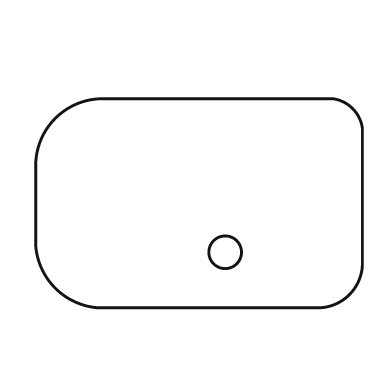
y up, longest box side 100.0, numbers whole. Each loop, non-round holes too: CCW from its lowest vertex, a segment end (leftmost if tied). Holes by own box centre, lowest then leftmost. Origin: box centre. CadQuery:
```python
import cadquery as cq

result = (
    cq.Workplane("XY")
    .moveTo(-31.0, -32.0)
    .lineTo(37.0, -32.0)
    .threePointArc((46.0, -28.0), (50.0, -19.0))
    .lineTo(50.0, 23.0)
    .threePointArc((47.0, 29.0), (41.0, 32.0))
    .lineTo(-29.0, 32.0)
    .threePointArc((-44.0, 26.0), (-50.0, 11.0))
    .lineTo(-50.0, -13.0)
    .threePointArc((-44.0, -26.0), (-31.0, -32.0))
    .close()
    .moveTo(8.0, -15.0)
    .circle(5.0)
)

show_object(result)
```